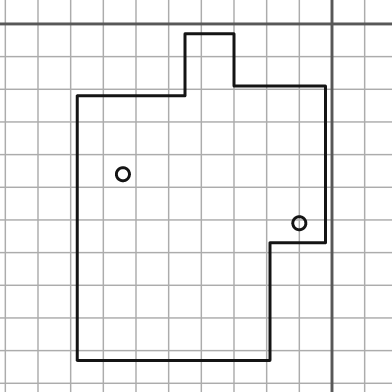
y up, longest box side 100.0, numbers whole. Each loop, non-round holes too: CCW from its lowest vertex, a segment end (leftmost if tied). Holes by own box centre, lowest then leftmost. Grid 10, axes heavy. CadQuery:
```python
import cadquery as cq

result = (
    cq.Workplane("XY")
    .moveTo(-78.0, -103.0)
    .lineTo(-19.0, -103.0)
    .lineTo(-19.0, -67.0)
    .lineTo(-2.0, -67.0)
    .lineTo(-2.0, -19.0)
    .lineTo(-30.0, -19.0)
    .lineTo(-30.0, -3.0)
    .lineTo(-45.0, -3.0)
    .lineTo(-45.0, -22.0)
    .lineTo(-78.0, -22.0)
    .close()
    .moveTo(-10.0, -61.0)
    .circle(2.0)
    .moveTo(-64.0, -46.0)
    .circle(2.0)
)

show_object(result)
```